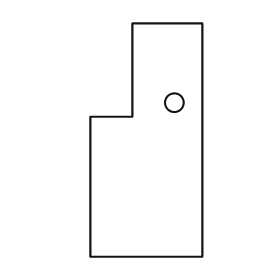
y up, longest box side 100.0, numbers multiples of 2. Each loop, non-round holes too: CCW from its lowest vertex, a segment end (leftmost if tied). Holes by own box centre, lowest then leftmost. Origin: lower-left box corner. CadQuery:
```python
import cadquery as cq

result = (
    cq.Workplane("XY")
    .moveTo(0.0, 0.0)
    .lineTo(48.0, 0.0)
    .lineTo(48.0, 100.0)
    .lineTo(18.0, 100.0)
    .lineTo(18.0, 60.0)
    .lineTo(0.0, 60.0)
    .close()
    .moveTo(36.0, 66.0)
    .circle(4.0)
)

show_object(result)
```